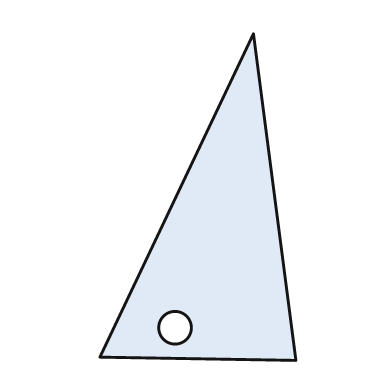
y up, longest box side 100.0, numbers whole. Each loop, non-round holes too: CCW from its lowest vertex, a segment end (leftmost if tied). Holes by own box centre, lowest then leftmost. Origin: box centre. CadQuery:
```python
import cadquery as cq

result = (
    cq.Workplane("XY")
    .moveTo(30.0, -50.0)
    .lineTo(17.0, 50.0)
    .lineTo(-30.0, -49.0)
    .close()
    .moveTo(-7.0, -40.0)
    .circle(5.0)
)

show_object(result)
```